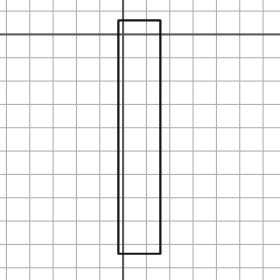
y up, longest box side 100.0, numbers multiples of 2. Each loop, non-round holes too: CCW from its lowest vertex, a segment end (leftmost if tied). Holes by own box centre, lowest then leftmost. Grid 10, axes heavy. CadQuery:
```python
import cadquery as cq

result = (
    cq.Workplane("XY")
    .moveTo(-2.0, -94.0)
    .lineTo(16.0, -94.0)
    .lineTo(16.0, 6.0)
    .lineTo(-2.0, 6.0)
    .close()
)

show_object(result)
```